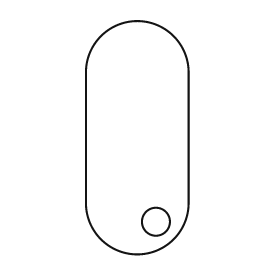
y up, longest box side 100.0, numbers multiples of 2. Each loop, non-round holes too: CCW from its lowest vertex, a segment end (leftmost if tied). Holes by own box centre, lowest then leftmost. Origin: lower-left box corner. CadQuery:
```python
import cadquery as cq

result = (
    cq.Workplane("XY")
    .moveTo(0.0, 22.0)
    .threePointArc((22.0, 0.0), (44.0, 22.0))
    .lineTo(44.0, 78.0)
    .threePointArc((22.0, 100.0), (0.0, 78.0))
    .close()
    .moveTo(30.0, 14.0)
    .circle(6.0)
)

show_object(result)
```